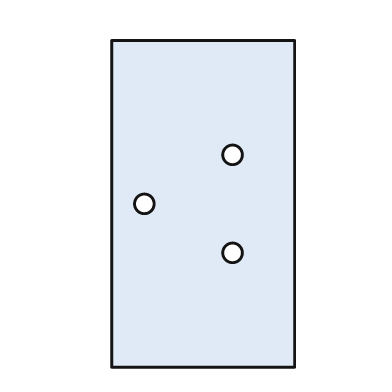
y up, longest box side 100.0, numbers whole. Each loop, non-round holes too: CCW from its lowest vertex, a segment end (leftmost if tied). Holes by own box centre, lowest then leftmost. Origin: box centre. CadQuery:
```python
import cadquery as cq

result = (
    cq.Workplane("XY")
    .moveTo(-28.0, -50.0)
    .lineTo(28.0, -50.0)
    .lineTo(28.0, 50.0)
    .lineTo(-28.0, 50.0)
    .close()
    .moveTo(9.0, -15.0)
    .circle(3.0)
    .moveTo(-18.0, 0.0)
    .circle(3.0)
    .moveTo(9.0, 15.0)
    .circle(3.0)
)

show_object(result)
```